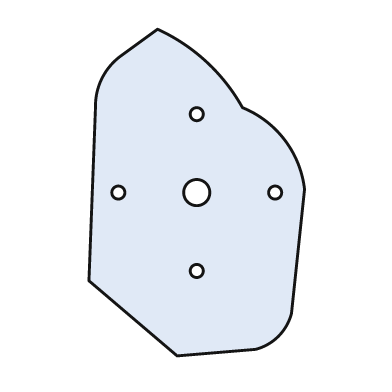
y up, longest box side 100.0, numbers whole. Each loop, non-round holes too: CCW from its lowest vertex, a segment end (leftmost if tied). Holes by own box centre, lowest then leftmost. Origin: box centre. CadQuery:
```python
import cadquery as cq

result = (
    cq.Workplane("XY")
    .moveTo(-6.0, -50.0)
    .lineTo(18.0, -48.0)
    .threePointArc((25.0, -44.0), (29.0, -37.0))
    .lineTo(33.0, 1.0)
    .threePointArc((27.0, 16.0), (14.0, 26.0))
    .threePointArc((3.0, 40.0), (-12.0, 50.0))
    .lineTo(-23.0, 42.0)
    .threePointArc((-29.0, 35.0), (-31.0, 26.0))
    .lineTo(-33.0, -27.0)
    .close()
    .moveTo(0.0, -24.0)
    .circle(2.0)
    .moveTo(-24.0, 0.0)
    .circle(2.0)
    .moveTo(0.0, 0.0)
    .circle(4.0)
    .moveTo(24.0, 0.0)
    .circle(2.0)
    .moveTo(0.0, 24.0)
    .circle(2.0)
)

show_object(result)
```